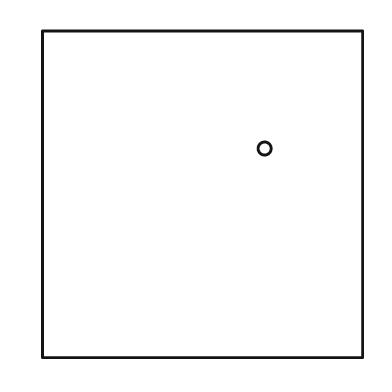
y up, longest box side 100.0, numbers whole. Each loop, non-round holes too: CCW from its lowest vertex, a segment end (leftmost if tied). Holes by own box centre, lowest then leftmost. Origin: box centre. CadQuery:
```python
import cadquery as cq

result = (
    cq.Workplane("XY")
    .moveTo(-49.0, -50.0)
    .lineTo(49.0, -50.0)
    .lineTo(49.0, 50.0)
    .lineTo(-49.0, 50.0)
    .close()
    .moveTo(19.0, 14.0)
    .circle(2.0)
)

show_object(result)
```